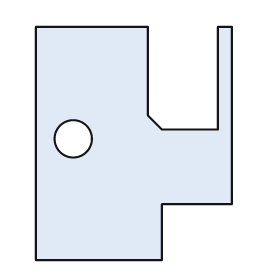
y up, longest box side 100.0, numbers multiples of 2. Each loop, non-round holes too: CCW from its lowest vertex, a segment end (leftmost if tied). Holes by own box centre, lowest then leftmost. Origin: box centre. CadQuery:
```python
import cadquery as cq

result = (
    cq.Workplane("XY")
    .moveTo(-42.0, -50.0)
    .lineTo(12.0, -50.0)
    .lineTo(12.0, -26.0)
    .lineTo(42.0, -26.0)
    .lineTo(42.0, 50.0)
    .lineTo(36.0, 50.0)
    .lineTo(36.0, 6.0)
    .lineTo(12.0, 6.0)
    .lineTo(6.0, 12.0)
    .lineTo(6.0, 50.0)
    .lineTo(-42.0, 50.0)
    .close()
    .moveTo(-26.0, 2.0)
    .circle(8.0)
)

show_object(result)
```